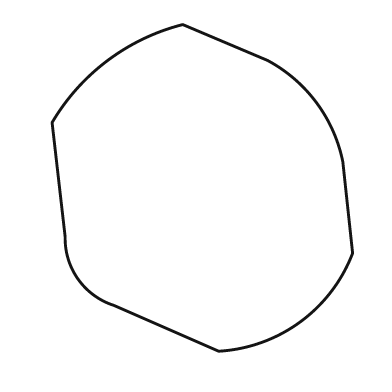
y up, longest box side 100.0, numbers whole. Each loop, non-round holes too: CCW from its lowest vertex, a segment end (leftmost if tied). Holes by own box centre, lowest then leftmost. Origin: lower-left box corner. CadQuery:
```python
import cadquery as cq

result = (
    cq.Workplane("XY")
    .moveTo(51.0, 0.0)
    .threePointArc((76.0, 9.0), (92.0, 30.0))
    .lineTo(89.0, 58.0)
    .threePointArc((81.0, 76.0), (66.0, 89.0))
    .lineTo(40.0, 100.0)
    .threePointArc((17.0, 89.0), (0.0, 70.0))
    .lineTo(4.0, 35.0)
    .threePointArc((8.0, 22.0), (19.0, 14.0))
    .close()
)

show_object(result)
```